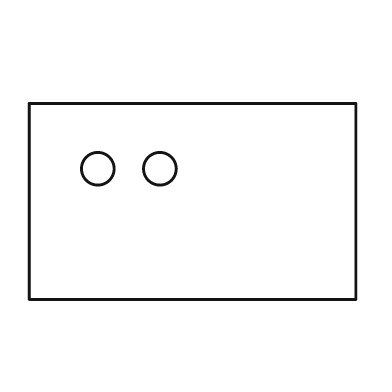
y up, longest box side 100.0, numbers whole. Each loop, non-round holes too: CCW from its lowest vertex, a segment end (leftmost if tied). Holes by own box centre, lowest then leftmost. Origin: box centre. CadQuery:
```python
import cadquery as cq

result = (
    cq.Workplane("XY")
    .moveTo(-50.0, -30.0)
    .lineTo(50.0, -30.0)
    .lineTo(50.0, 30.0)
    .lineTo(-50.0, 30.0)
    .close()
    .moveTo(-29.0, 10.0)
    .circle(5.0)
    .moveTo(-10.0, 10.0)
    .circle(5.0)
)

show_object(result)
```